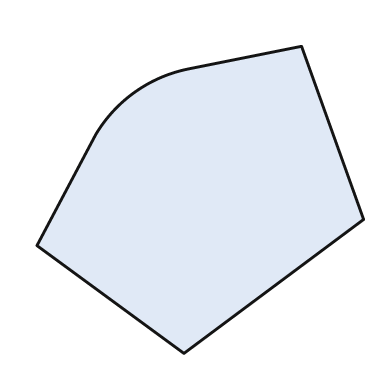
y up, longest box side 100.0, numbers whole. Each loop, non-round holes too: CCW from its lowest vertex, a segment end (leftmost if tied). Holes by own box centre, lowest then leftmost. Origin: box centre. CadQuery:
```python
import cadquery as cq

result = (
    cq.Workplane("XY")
    .moveTo(-5.0, -47.0)
    .lineTo(50.0, -6.0)
    .lineTo(31.0, 47.0)
    .lineTo(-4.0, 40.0)
    .threePointArc((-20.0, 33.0), (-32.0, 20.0))
    .lineTo(-50.0, -14.0)
    .close()
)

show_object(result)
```